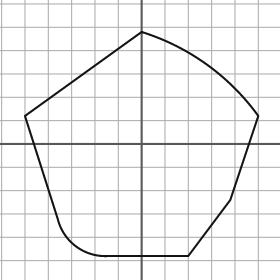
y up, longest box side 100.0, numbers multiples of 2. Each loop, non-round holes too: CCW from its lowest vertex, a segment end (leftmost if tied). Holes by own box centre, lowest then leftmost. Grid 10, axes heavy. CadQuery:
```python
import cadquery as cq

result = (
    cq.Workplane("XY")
    .moveTo(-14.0, -48.0)
    .lineTo(20.0, -48.0)
    .lineTo(38.0, -24.0)
    .lineTo(50.0, 12.0)
    .threePointArc((28.0, 34.0), (0.0, 48.0))
    .lineTo(-50.0, 12.0)
    .lineTo(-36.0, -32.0)
    .threePointArc((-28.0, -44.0), (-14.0, -48.0))
    .close()
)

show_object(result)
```